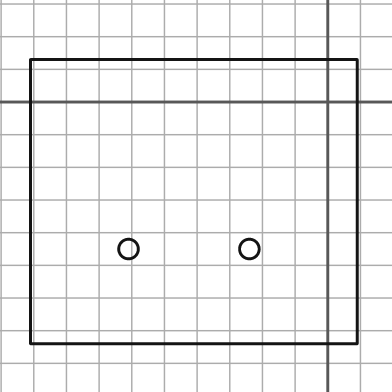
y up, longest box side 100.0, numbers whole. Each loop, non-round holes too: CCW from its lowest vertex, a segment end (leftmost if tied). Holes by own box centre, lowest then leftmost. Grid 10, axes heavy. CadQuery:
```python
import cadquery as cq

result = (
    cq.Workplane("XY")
    .moveTo(-91.0, -74.0)
    .lineTo(9.0, -74.0)
    .lineTo(9.0, 13.0)
    .lineTo(-91.0, 13.0)
    .close()
    .moveTo(-61.0, -45.0)
    .circle(3.0)
    .moveTo(-24.0, -45.0)
    .circle(3.0)
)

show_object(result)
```